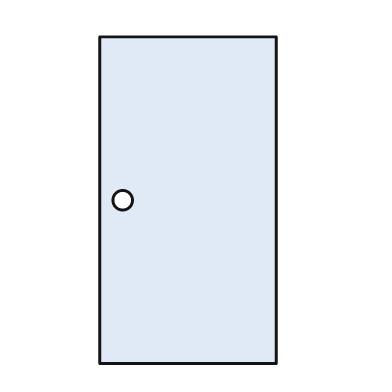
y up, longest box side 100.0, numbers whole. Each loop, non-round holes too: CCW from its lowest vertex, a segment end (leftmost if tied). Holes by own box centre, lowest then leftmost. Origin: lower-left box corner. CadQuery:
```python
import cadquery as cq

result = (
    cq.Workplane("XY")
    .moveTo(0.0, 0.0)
    .lineTo(54.0, 0.0)
    .lineTo(54.0, 100.0)
    .lineTo(0.0, 100.0)
    .close()
    .moveTo(7.0, 50.0)
    .circle(3.0)
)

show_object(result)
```